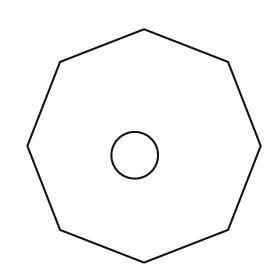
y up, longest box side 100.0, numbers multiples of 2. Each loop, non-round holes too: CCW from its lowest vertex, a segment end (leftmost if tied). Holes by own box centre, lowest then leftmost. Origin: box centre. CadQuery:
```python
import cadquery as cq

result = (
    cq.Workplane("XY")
    .moveTo(0.0, -50.0)
    .lineTo(36.0, -36.0)
    .lineTo(50.0, 0.0)
    .lineTo(36.0, 36.0)
    .lineTo(0.0, 50.0)
    .lineTo(-36.0, 36.0)
    .lineTo(-50.0, 0.0)
    .lineTo(-36.0, -36.0)
    .close()
    .moveTo(-4.0, -4.0)
    .circle(10.0)
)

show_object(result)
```